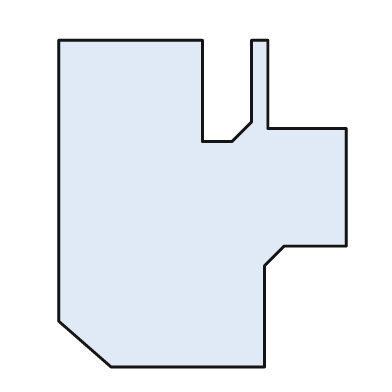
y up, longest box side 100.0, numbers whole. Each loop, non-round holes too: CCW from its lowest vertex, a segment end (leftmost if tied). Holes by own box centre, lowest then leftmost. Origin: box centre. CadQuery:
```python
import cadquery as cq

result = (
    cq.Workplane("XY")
    .moveTo(-28.0, -50.0)
    .lineTo(19.0, -50.0)
    .lineTo(19.0, -19.0)
    .lineTo(25.0, -13.0)
    .lineTo(44.0, -13.0)
    .lineTo(44.0, 23.0)
    .lineTo(20.0, 23.0)
    .lineTo(20.0, 50.0)
    .lineTo(15.0, 50.0)
    .lineTo(15.0, 25.0)
    .lineTo(9.0, 19.0)
    .lineTo(0.0, 19.0)
    .lineTo(0.0, 50.0)
    .lineTo(-44.0, 50.0)
    .lineTo(-44.0, -36.0)
    .close()
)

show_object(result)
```